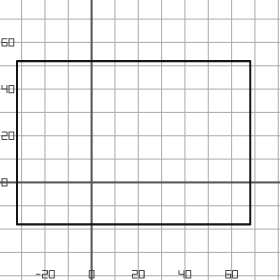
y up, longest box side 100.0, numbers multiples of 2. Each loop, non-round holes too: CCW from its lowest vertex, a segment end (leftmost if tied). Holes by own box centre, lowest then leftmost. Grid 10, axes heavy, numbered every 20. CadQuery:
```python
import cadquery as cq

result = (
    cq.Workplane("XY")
    .moveTo(-32.0, -18.0)
    .lineTo(68.0, -18.0)
    .lineTo(68.0, 52.0)
    .lineTo(-32.0, 52.0)
    .close()
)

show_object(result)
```